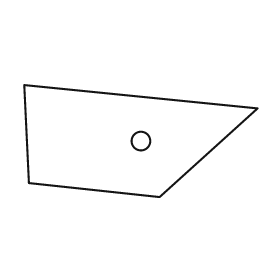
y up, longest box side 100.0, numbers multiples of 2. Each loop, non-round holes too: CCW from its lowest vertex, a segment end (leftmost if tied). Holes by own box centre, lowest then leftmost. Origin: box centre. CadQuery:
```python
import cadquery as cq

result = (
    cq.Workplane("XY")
    .moveTo(8.0, -24.0)
    .lineTo(50.0, 14.0)
    .lineTo(-50.0, 24.0)
    .lineTo(-48.0, -18.0)
    .close()
    .moveTo(0.0, 0.0)
    .circle(4.0)
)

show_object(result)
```